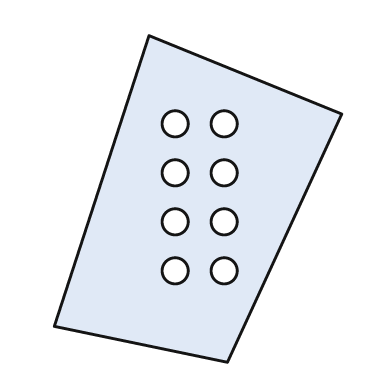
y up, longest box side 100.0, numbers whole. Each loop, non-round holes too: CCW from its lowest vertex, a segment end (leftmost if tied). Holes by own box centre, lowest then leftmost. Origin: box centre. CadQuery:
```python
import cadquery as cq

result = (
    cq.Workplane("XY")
    .moveTo(9.0, -50.0)
    .lineTo(44.0, 26.0)
    .lineTo(-15.0, 50.0)
    .lineTo(-44.0, -39.0)
    .close()
    .moveTo(-7.0, -22.0)
    .circle(4.0)
    .moveTo(8.0, -22.0)
    .circle(4.0)
    .moveTo(-7.0, -7.0)
    .circle(4.0)
    .moveTo(8.0, -7.0)
    .circle(4.0)
    .moveTo(-7.0, 8.0)
    .circle(4.0)
    .moveTo(8.0, 8.0)
    .circle(4.0)
    .moveTo(-7.0, 23.0)
    .circle(4.0)
    .moveTo(8.0, 23.0)
    .circle(4.0)
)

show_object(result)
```